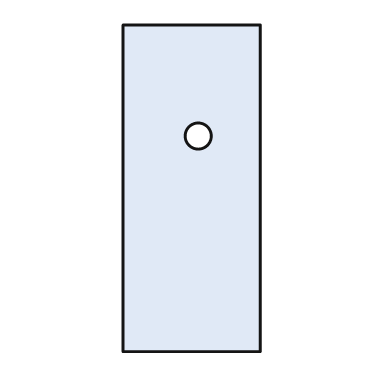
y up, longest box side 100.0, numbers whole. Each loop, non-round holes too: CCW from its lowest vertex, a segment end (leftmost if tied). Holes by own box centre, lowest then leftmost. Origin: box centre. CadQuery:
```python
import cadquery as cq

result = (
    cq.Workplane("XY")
    .moveTo(-21.0, -50.0)
    .lineTo(21.0, -50.0)
    .lineTo(21.0, 50.0)
    .lineTo(-21.0, 50.0)
    .close()
    .moveTo(2.0, 16.0)
    .circle(4.0)
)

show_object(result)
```